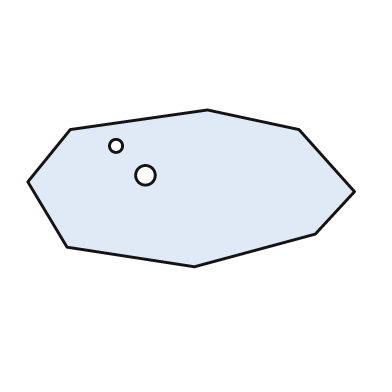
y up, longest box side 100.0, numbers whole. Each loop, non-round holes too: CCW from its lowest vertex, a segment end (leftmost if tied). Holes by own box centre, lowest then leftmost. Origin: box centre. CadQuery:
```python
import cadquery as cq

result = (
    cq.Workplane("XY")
    .moveTo(1.0, -24.0)
    .lineTo(38.0, -14.0)
    .lineTo(50.0, -1.0)
    .lineTo(33.0, 18.0)
    .lineTo(5.0, 24.0)
    .lineTo(-37.0, 18.0)
    .lineTo(-50.0, 2.0)
    .lineTo(-38.0, -18.0)
    .close()
    .moveTo(-14.0, 4.0)
    .circle(3.0)
    .moveTo(-23.0, 13.0)
    .circle(2.0)
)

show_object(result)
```